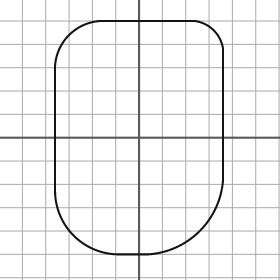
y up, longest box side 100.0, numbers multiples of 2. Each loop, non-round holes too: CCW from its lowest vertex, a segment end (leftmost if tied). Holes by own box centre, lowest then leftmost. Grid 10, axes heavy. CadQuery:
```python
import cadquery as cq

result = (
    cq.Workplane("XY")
    .moveTo(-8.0, -50.0)
    .lineTo(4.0, -50.0)
    .threePointArc((26.0, -40.0), (36.0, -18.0))
    .lineTo(36.0, 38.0)
    .threePointArc((32.0, 46.0), (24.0, 50.0))
    .lineTo(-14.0, 50.0)
    .threePointArc((-30.0, 44.0), (-36.0, 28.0))
    .lineTo(-36.0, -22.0)
    .threePointArc((-28.0, -42.0), (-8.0, -50.0))
    .close()
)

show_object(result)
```